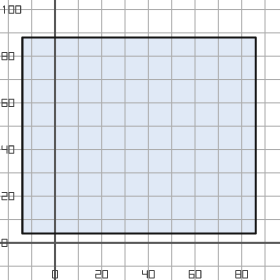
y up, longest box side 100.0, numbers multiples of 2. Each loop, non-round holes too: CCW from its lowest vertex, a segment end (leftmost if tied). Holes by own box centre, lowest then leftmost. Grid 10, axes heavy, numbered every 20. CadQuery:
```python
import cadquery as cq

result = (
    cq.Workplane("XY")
    .moveTo(-14.0, 4.0)
    .lineTo(86.0, 4.0)
    .lineTo(86.0, 88.0)
    .lineTo(-14.0, 88.0)
    .close()
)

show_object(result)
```